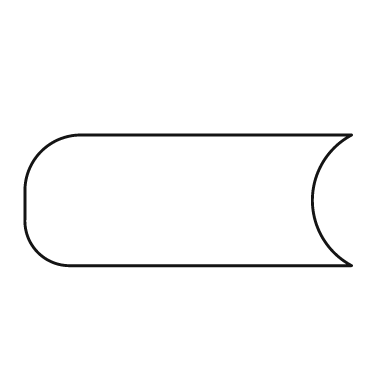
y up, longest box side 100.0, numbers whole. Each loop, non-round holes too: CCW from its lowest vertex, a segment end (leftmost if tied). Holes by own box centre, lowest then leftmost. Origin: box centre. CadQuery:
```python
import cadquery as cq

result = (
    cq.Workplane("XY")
    .moveTo(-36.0, -20.0)
    .lineTo(50.0, -20.0)
    .threePointArc((38.0, 0.0), (50.0, 20.0))
    .lineTo(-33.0, 20.0)
    .threePointArc((-45.0, 15.0), (-50.0, 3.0))
    .lineTo(-50.0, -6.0)
    .threePointArc((-46.0, -16.0), (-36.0, -20.0))
    .close()
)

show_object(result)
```